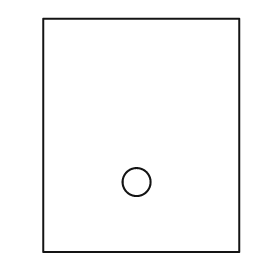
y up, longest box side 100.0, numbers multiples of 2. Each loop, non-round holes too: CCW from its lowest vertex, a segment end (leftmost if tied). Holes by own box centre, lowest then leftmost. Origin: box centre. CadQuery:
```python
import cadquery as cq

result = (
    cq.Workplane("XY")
    .moveTo(-42.0, -50.0)
    .lineTo(42.0, -50.0)
    .lineTo(42.0, 50.0)
    .lineTo(-42.0, 50.0)
    .close()
    .moveTo(-2.0, -20.0)
    .circle(6.0)
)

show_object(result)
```